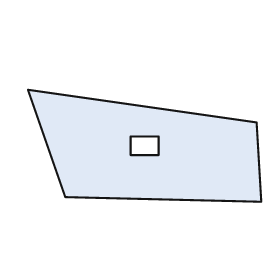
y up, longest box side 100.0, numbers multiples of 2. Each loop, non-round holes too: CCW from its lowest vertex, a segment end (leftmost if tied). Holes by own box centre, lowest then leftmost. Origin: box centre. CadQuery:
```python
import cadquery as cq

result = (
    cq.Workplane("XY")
    .moveTo(50.0, -24.0)
    .lineTo(48.0, 10.0)
    .lineTo(-50.0, 24.0)
    .lineTo(-34.0, -22.0)
    .close()
    .moveTo(-6.0, -4.0)
    .lineTo(6.0, -4.0)
    .lineTo(6.0, 4.0)
    .lineTo(-6.0, 4.0)
    .close()
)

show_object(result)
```